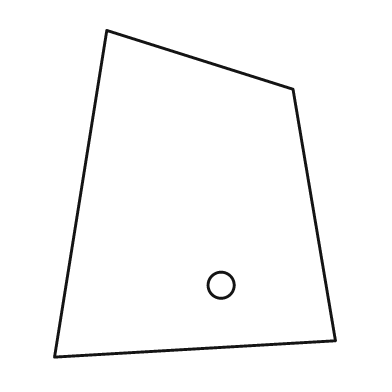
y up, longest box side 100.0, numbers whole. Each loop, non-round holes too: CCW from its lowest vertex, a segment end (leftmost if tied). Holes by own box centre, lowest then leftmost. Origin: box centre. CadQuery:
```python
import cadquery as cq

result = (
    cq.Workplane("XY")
    .moveTo(-43.0, -50.0)
    .lineTo(43.0, -45.0)
    .lineTo(30.0, 32.0)
    .lineTo(-27.0, 50.0)
    .close()
    .moveTo(8.0, -28.0)
    .circle(4.0)
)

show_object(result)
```